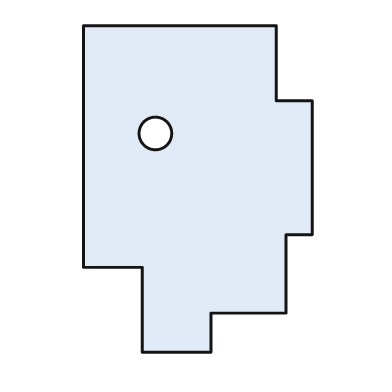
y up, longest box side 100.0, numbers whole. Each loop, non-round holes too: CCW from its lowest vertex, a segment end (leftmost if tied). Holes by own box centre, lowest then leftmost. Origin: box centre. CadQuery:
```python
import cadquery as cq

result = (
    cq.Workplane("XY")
    .moveTo(-17.0, -50.0)
    .lineTo(4.0, -50.0)
    .lineTo(4.0, -38.0)
    .lineTo(27.0, -38.0)
    .lineTo(27.0, -14.0)
    .lineTo(35.0, -14.0)
    .lineTo(35.0, 27.0)
    .lineTo(24.0, 27.0)
    .lineTo(24.0, 50.0)
    .lineTo(-35.0, 50.0)
    .lineTo(-35.0, -24.0)
    .lineTo(-17.0, -24.0)
    .close()
    .moveTo(-13.0, 17.0)
    .circle(5.0)
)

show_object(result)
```